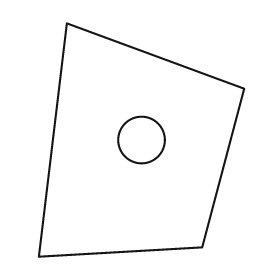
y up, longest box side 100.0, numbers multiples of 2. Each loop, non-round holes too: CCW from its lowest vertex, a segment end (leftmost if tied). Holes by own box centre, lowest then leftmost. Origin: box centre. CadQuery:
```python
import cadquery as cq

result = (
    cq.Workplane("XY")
    .moveTo(-44.0, -50.0)
    .lineTo(26.0, -46.0)
    .lineTo(44.0, 22.0)
    .lineTo(-32.0, 50.0)
    .close()
    .moveTo(0.0, 0.0)
    .circle(10.0)
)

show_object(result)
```